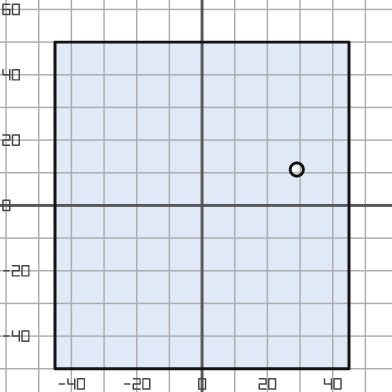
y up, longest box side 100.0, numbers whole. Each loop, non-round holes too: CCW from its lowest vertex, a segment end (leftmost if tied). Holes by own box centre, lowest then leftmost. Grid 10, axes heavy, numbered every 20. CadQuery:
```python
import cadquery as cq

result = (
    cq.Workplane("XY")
    .moveTo(-45.0, -50.0)
    .lineTo(45.0, -50.0)
    .lineTo(45.0, 50.0)
    .lineTo(-45.0, 50.0)
    .close()
    .moveTo(29.0, 11.0)
    .circle(2.0)
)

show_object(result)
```